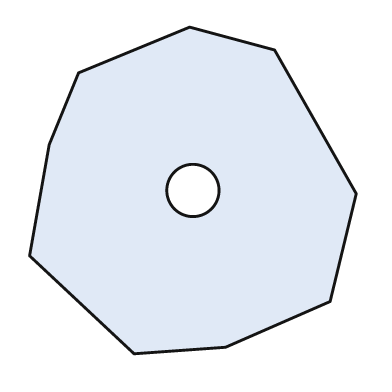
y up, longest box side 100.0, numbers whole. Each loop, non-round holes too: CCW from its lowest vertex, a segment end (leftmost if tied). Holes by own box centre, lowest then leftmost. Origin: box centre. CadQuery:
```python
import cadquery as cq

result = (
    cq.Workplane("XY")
    .moveTo(-18.0, -50.0)
    .lineTo(10.0, -48.0)
    .lineTo(42.0, -34.0)
    .lineTo(50.0, -1.0)
    .lineTo(25.0, 43.0)
    .lineTo(-1.0, 50.0)
    .lineTo(-35.0, 36.0)
    .lineTo(-44.0, 14.0)
    .lineTo(-50.0, -20.0)
    .close()
    .moveTo(0.0, 0.0)
    .circle(8.0)
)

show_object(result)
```